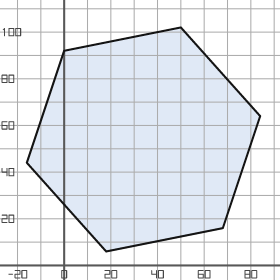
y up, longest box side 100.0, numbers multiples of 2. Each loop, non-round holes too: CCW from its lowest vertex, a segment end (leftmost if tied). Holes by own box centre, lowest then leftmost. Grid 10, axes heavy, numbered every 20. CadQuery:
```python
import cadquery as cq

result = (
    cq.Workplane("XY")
    .moveTo(18.0, 6.0)
    .lineTo(68.0, 16.0)
    .lineTo(84.0, 64.0)
    .lineTo(50.0, 102.0)
    .lineTo(0.0, 92.0)
    .lineTo(-16.0, 44.0)
    .close()
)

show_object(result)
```